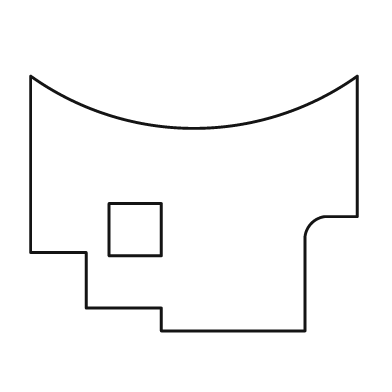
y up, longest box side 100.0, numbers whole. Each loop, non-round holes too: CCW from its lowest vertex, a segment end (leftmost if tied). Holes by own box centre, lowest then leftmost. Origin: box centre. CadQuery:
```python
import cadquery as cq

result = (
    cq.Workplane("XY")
    .moveTo(-10.0, -39.0)
    .lineTo(34.0, -39.0)
    .lineTo(34.0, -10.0)
    .threePointArc((36.0, -6.0), (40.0, -4.0))
    .lineTo(50.0, -4.0)
    .lineTo(50.0, 39.0)
    .threePointArc((0.0, 23.0), (-50.0, 39.0))
    .lineTo(-50.0, -15.0)
    .lineTo(-33.0, -15.0)
    .lineTo(-33.0, -32.0)
    .lineTo(-10.0, -32.0)
    .close()
    .moveTo(-26.0, -16.0)
    .lineTo(-10.0, -16.0)
    .lineTo(-10.0, 0.0)
    .lineTo(-26.0, 0.0)
    .close()
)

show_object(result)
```